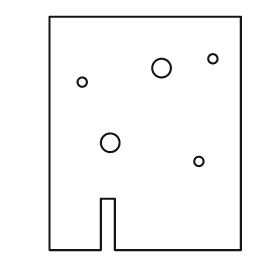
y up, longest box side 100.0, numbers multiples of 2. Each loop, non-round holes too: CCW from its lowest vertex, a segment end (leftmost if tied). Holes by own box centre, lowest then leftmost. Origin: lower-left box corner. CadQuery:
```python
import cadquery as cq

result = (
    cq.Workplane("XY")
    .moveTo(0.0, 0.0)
    .lineTo(22.0, 0.0)
    .lineTo(22.0, 22.0)
    .lineTo(28.0, 22.0)
    .lineTo(28.0, 0.0)
    .lineTo(82.0, 0.0)
    .lineTo(82.0, 100.0)
    .lineTo(0.0, 100.0)
    .close()
    .moveTo(64.0, 38.0)
    .circle(2.0)
    .moveTo(26.0, 46.0)
    .circle(4.0)
    .moveTo(14.0, 72.0)
    .circle(2.0)
    .moveTo(48.0, 78.0)
    .circle(4.0)
    .moveTo(70.0, 82.0)
    .circle(2.0)
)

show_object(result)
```